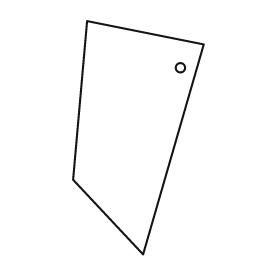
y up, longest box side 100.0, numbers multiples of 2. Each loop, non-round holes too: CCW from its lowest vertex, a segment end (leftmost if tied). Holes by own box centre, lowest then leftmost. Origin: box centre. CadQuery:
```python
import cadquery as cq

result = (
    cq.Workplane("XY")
    .moveTo(2.0, -50.0)
    .lineTo(28.0, 40.0)
    .lineTo(-22.0, 50.0)
    .lineTo(-28.0, -18.0)
    .close()
    .moveTo(18.0, 30.0)
    .circle(2.0)
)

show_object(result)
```